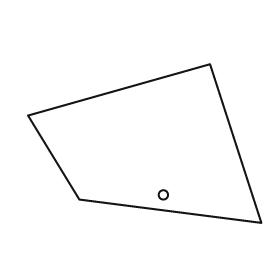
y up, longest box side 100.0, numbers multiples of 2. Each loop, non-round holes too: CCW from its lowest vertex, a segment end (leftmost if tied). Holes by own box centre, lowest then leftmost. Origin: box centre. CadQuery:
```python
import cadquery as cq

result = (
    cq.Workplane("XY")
    .moveTo(50.0, -34.0)
    .lineTo(28.0, 34.0)
    .lineTo(-50.0, 12.0)
    .lineTo(-28.0, -24.0)
    .close()
    .moveTo(8.0, -22.0)
    .circle(2.0)
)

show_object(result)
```